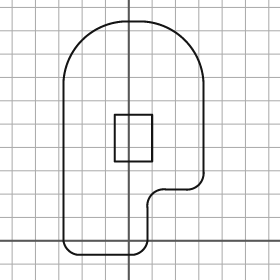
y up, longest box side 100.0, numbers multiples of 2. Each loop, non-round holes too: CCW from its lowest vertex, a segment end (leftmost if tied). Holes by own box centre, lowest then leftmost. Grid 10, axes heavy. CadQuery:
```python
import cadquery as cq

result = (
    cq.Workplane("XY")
    .moveTo(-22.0, -6.0)
    .lineTo(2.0, -6.0)
    .threePointArc((6.0, -4.0), (8.0, 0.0))
    .lineTo(8.0, 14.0)
    .threePointArc((10.0, 20.0), (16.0, 22.0))
    .lineTo(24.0, 22.0)
    .threePointArc((30.0, 24.0), (32.0, 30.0))
    .lineTo(32.0, 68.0)
    .threePointArc((24.0, 86.0), (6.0, 94.0))
    .lineTo(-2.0, 94.0)
    .threePointArc((-20.0, 86.0), (-28.0, 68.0))
    .lineTo(-28.0, 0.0)
    .threePointArc((-26.0, -4.0), (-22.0, -6.0))
    .close()
    .moveTo(-6.0, 34.0)
    .lineTo(10.0, 34.0)
    .lineTo(10.0, 54.0)
    .lineTo(-6.0, 54.0)
    .close()
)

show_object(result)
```